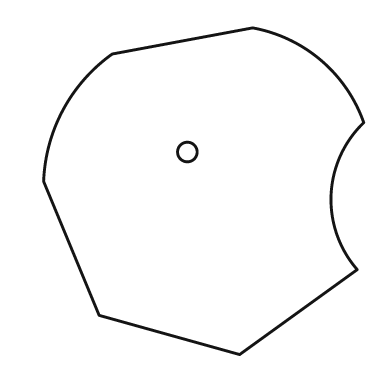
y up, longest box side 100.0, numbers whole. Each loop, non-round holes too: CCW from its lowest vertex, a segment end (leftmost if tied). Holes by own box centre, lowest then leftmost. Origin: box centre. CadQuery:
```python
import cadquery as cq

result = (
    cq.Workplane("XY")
    .moveTo(11.0, -50.0)
    .lineTo(47.0, -24.0)
    .threePointArc((39.0, -1.0), (49.0, 21.0))
    .threePointArc((36.0, 40.0), (15.0, 50.0))
    .lineTo(-28.0, 42.0)
    .threePointArc((-43.0, 25.0), (-49.0, 3.0))
    .lineTo(-32.0, -38.0)
    .close()
    .moveTo(-5.0, 12.0)
    .circle(3.0)
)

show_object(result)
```